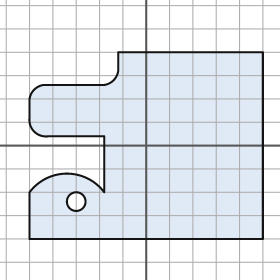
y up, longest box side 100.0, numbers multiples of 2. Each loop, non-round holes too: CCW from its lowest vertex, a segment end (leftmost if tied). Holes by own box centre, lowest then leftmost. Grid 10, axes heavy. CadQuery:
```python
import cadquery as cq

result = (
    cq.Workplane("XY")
    .moveTo(-50.0, -40.0)
    .lineTo(50.0, -40.0)
    .lineTo(50.0, 40.0)
    .lineTo(-12.0, 40.0)
    .lineTo(-12.0, 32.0)
    .threePointArc((-14.0, 28.0), (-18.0, 26.0))
    .lineTo(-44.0, 26.0)
    .threePointArc((-48.0, 24.0), (-50.0, 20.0))
    .lineTo(-50.0, 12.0)
    .threePointArc((-48.0, 6.0), (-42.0, 4.0))
    .lineTo(-18.0, 4.0)
    .lineTo(-18.0, -20.0)
    .threePointArc((-34.0, -12.0), (-50.0, -20.0))
    .close()
    .moveTo(-30.0, -24.0)
    .circle(4.0)
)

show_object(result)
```